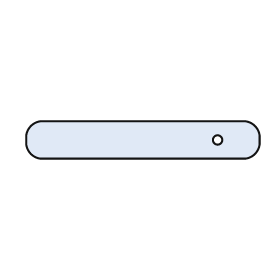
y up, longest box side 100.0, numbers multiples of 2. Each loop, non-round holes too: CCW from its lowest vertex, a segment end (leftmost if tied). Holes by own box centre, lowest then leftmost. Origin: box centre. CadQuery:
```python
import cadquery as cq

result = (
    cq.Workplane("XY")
    .moveTo(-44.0, -8.0)
    .lineTo(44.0, -8.0)
    .threePointArc((48.0, -6.0), (50.0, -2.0))
    .lineTo(50.0, 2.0)
    .threePointArc((48.0, 6.0), (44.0, 8.0))
    .lineTo(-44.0, 8.0)
    .threePointArc((-48.0, 6.0), (-50.0, 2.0))
    .lineTo(-50.0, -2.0)
    .threePointArc((-48.0, -6.0), (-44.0, -8.0))
    .close()
    .moveTo(32.0, 0.0)
    .circle(2.0)
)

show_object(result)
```